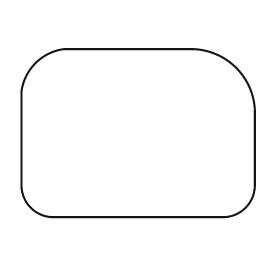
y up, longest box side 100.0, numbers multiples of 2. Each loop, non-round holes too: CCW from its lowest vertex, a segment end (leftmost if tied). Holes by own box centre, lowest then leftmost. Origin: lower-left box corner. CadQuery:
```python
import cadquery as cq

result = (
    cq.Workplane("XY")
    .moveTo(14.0, 0.0)
    .lineTo(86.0, 0.0)
    .threePointArc((96.0, 4.0), (100.0, 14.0))
    .lineTo(100.0, 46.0)
    .threePointArc((92.0, 64.0), (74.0, 72.0))
    .lineTo(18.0, 72.0)
    .threePointArc((6.0, 66.0), (0.0, 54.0))
    .lineTo(0.0, 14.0)
    .threePointArc((4.0, 4.0), (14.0, 0.0))
    .close()
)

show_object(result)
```